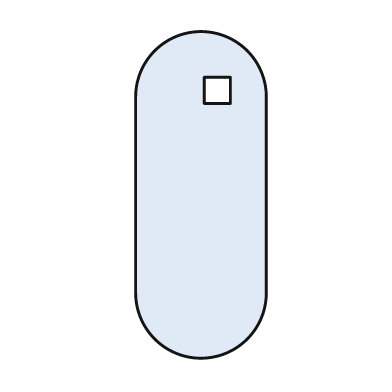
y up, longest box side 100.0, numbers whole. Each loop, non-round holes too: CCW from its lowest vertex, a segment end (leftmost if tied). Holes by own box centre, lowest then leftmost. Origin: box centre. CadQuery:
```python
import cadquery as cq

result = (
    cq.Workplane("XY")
    .moveTo(-20.0, -30.0)
    .threePointArc((0.0, -50.0), (20.0, -30.0))
    .lineTo(20.0, 30.0)
    .threePointArc((0.0, 50.0), (-20.0, 30.0))
    .close()
    .moveTo(1.0, 28.0)
    .lineTo(9.0, 28.0)
    .lineTo(9.0, 36.0)
    .lineTo(1.0, 36.0)
    .close()
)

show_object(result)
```